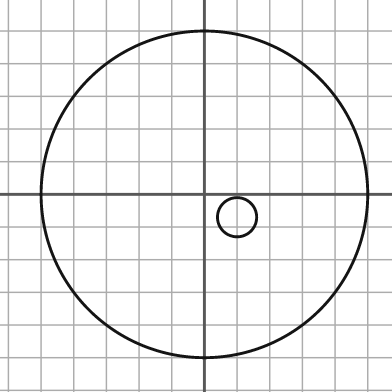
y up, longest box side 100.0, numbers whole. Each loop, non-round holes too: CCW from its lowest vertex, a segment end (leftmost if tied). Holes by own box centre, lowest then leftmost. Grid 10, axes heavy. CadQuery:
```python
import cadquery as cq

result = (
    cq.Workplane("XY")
    .moveTo(0.0, 0.0)
    .circle(50.0)
    .moveTo(10.0, -7.0)
    .circle(6.0)
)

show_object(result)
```